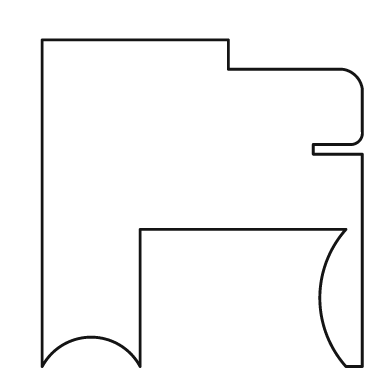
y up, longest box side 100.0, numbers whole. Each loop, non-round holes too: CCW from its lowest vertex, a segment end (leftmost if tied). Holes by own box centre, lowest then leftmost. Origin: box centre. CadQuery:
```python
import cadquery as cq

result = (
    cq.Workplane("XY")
    .moveTo(-49.0, -50.0)
    .threePointArc((-34.0, -41.0), (-19.0, -50.0))
    .lineTo(-19.0, -8.0)
    .lineTo(44.0, -8.0)
    .threePointArc((36.0, -29.0), (44.0, -50.0))
    .lineTo(49.0, -50.0)
    .lineTo(49.0, 15.0)
    .lineTo(34.0, 15.0)
    .lineTo(34.0, 18.0)
    .lineTo(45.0, 18.0)
    .threePointArc((48.0, 19.0), (49.0, 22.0))
    .lineTo(49.0, 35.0)
    .threePointArc((47.0, 39.0), (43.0, 41.0))
    .lineTo(8.0, 41.0)
    .lineTo(8.0, 50.0)
    .lineTo(-49.0, 50.0)
    .close()
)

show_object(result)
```